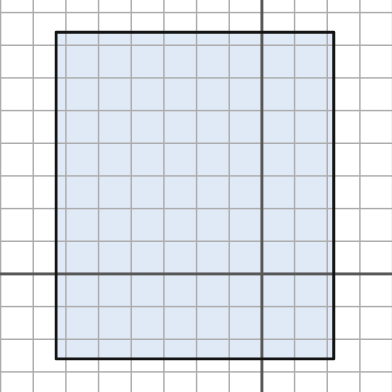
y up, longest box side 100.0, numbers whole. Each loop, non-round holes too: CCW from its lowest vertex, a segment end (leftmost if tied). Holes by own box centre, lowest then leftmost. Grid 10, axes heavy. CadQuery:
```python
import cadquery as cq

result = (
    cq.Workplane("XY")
    .moveTo(-63.0, -26.0)
    .lineTo(22.0, -26.0)
    .lineTo(22.0, 74.0)
    .lineTo(-63.0, 74.0)
    .close()
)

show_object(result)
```